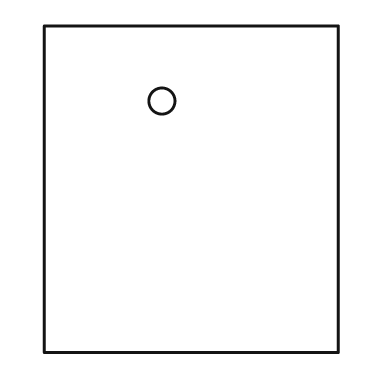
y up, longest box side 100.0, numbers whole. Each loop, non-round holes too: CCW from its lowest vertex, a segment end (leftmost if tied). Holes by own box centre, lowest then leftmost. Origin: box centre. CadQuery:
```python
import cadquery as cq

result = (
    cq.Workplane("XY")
    .moveTo(-45.0, -50.0)
    .lineTo(45.0, -50.0)
    .lineTo(45.0, 50.0)
    .lineTo(-45.0, 50.0)
    .close()
    .moveTo(-9.0, 27.0)
    .circle(4.0)
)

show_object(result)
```